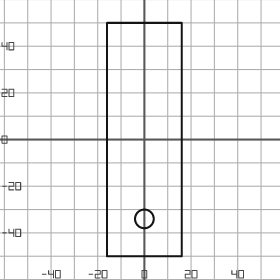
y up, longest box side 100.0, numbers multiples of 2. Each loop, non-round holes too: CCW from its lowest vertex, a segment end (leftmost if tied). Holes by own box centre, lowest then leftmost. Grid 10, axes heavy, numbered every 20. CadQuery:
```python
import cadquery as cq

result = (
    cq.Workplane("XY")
    .moveTo(-16.0, -50.0)
    .lineTo(16.0, -50.0)
    .lineTo(16.0, 50.0)
    .lineTo(-16.0, 50.0)
    .close()
    .moveTo(0.0, -34.0)
    .circle(4.0)
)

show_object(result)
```